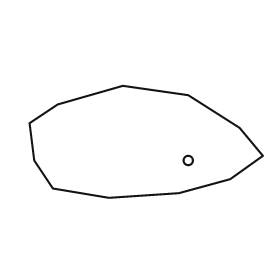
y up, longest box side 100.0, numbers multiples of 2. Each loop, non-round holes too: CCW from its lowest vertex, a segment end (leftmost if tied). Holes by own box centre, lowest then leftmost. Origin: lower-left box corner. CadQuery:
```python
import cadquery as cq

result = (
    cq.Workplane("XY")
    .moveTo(34.0, 0.0)
    .lineTo(64.0, 2.0)
    .lineTo(86.0, 8.0)
    .lineTo(100.0, 18.0)
    .lineTo(90.0, 30.0)
    .lineTo(68.0, 44.0)
    .lineTo(40.0, 48.0)
    .lineTo(12.0, 40.0)
    .lineTo(0.0, 32.0)
    .lineTo(2.0, 16.0)
    .lineTo(10.0, 4.0)
    .close()
    .moveTo(68.0, 16.0)
    .circle(2.0)
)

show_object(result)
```